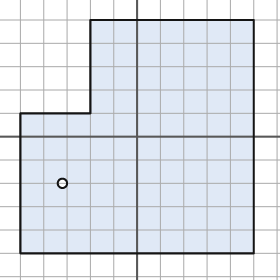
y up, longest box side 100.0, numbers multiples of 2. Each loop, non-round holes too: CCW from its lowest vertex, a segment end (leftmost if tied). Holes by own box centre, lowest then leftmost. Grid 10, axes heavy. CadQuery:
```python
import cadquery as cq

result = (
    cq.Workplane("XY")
    .moveTo(-50.0, -50.0)
    .lineTo(50.0, -50.0)
    .lineTo(50.0, 50.0)
    .lineTo(-20.0, 50.0)
    .lineTo(-20.0, 10.0)
    .lineTo(-50.0, 10.0)
    .close()
    .moveTo(-32.0, -20.0)
    .circle(2.0)
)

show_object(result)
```